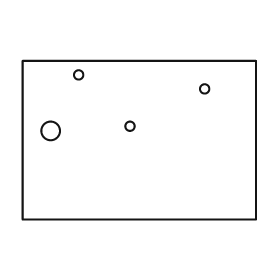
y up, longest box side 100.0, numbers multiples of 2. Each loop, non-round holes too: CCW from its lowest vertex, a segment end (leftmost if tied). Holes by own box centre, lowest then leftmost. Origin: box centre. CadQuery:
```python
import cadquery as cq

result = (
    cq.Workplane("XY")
    .moveTo(-50.0, -34.0)
    .lineTo(50.0, -34.0)
    .lineTo(50.0, 34.0)
    .lineTo(-50.0, 34.0)
    .close()
    .moveTo(-38.0, 4.0)
    .circle(4.0)
    .moveTo(-4.0, 6.0)
    .circle(2.0)
    .moveTo(28.0, 22.0)
    .circle(2.0)
    .moveTo(-26.0, 28.0)
    .circle(2.0)
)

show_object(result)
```